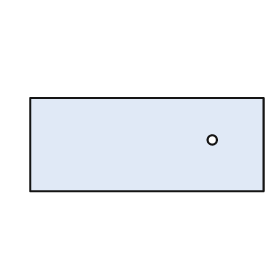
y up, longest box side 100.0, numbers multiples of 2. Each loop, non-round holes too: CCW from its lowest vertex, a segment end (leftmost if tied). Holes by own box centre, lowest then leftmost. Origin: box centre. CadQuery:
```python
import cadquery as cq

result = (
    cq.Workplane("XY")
    .moveTo(-50.0, -20.0)
    .lineTo(50.0, -20.0)
    .lineTo(50.0, 20.0)
    .lineTo(-50.0, 20.0)
    .close()
    .moveTo(28.0, 2.0)
    .circle(2.0)
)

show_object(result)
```